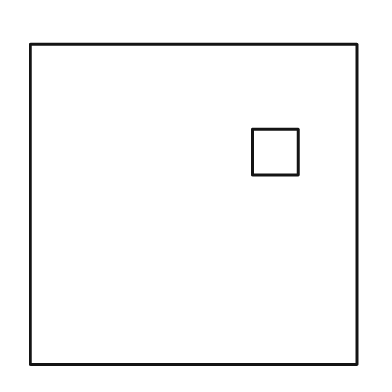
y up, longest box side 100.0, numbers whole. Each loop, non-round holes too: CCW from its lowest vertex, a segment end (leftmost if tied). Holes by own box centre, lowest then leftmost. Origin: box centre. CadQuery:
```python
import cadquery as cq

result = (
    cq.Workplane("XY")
    .moveTo(-50.0, -49.0)
    .lineTo(50.0, -49.0)
    .lineTo(50.0, 49.0)
    .lineTo(-50.0, 49.0)
    .close()
    .moveTo(18.0, 9.0)
    .lineTo(32.0, 9.0)
    .lineTo(32.0, 23.0)
    .lineTo(18.0, 23.0)
    .close()
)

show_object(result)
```